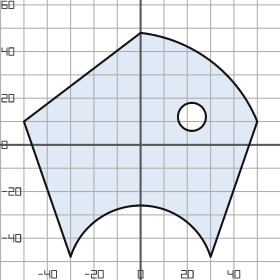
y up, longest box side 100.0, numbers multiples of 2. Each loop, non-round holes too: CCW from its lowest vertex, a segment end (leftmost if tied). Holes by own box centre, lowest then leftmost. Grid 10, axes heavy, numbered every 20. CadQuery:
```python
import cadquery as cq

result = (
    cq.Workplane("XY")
    .moveTo(-30.0, -48.0)
    .threePointArc((0.0, -26.0), (30.0, -48.0))
    .lineTo(50.0, 10.0)
    .threePointArc((30.0, 36.0), (0.0, 48.0))
    .lineTo(-50.0, 10.0)
    .close()
    .moveTo(22.0, 12.0)
    .circle(6.0)
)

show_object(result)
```